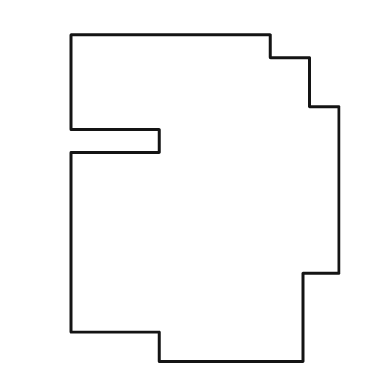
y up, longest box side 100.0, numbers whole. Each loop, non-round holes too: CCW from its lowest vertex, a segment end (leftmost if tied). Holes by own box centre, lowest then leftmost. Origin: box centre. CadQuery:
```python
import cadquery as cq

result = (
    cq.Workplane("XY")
    .moveTo(-14.0, -50.0)
    .lineTo(30.0, -50.0)
    .lineTo(30.0, -23.0)
    .lineTo(41.0, -23.0)
    .lineTo(41.0, 28.0)
    .lineTo(32.0, 28.0)
    .lineTo(32.0, 43.0)
    .lineTo(20.0, 43.0)
    .lineTo(20.0, 50.0)
    .lineTo(-41.0, 50.0)
    .lineTo(-41.0, 21.0)
    .lineTo(-14.0, 21.0)
    .lineTo(-14.0, 14.0)
    .lineTo(-41.0, 14.0)
    .lineTo(-41.0, -41.0)
    .lineTo(-14.0, -41.0)
    .close()
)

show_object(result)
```